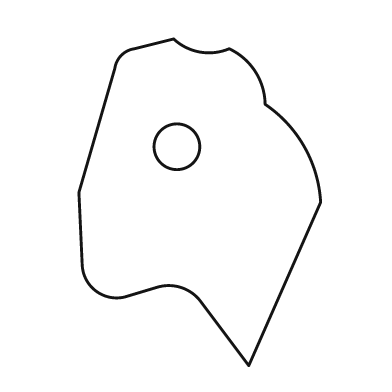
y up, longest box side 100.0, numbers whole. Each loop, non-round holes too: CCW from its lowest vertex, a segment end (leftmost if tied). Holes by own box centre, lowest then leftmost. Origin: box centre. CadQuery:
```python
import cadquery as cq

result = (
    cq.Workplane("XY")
    .moveTo(15.0, -50.0)
    .lineTo(37.0, 0.0)
    .threePointArc((32.0, 17.0), (20.0, 30.0))
    .threePointArc((17.0, 40.0), (9.0, 47.0))
    .threePointArc((0.0, 46.0), (-8.0, 50.0))
    .lineTo(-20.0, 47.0)
    .threePointArc((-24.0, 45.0), (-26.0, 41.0))
    .lineTo(-37.0, 3.0)
    .lineTo(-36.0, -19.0)
    .threePointArc((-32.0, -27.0), (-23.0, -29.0))
    .lineTo(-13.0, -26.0)
    .threePointArc((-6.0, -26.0), (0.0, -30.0))
    .close()
    .moveTo(-7.0, 17.0)
    .circle(7.0)
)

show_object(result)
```